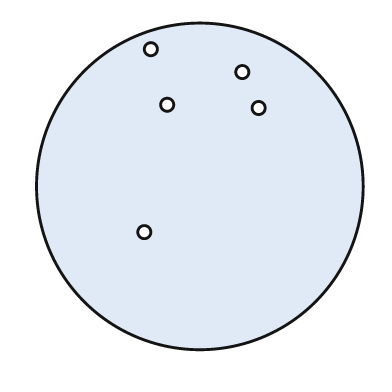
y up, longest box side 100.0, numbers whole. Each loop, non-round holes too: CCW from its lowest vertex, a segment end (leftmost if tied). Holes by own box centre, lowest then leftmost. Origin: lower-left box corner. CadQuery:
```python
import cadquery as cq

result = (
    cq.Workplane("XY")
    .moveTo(50.0, 50.0)
    .circle(50.0)
    .moveTo(33.0, 36.0)
    .circle(2.0)
    .moveTo(68.0, 74.0)
    .circle(2.0)
    .moveTo(40.0, 75.0)
    .circle(2.0)
    .moveTo(63.0, 85.0)
    .circle(2.0)
    .moveTo(35.0, 92.0)
    .circle(2.0)
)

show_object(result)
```